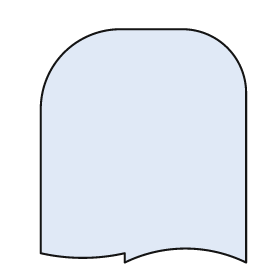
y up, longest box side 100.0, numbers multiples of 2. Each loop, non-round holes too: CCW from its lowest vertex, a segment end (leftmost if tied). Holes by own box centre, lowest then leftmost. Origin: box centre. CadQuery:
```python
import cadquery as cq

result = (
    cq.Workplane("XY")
    .moveTo(-8.0, -50.0)
    .threePointArc((18.0, -44.0), (44.0, -50.0))
    .lineTo(44.0, 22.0)
    .threePointArc((36.0, 42.0), (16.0, 50.0))
    .lineTo(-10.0, 50.0)
    .threePointArc((-34.0, 40.0), (-44.0, 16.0))
    .lineTo(-44.0, -46.0)
    .threePointArc((-26.0, -48.0), (-8.0, -46.0))
    .close()
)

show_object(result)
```